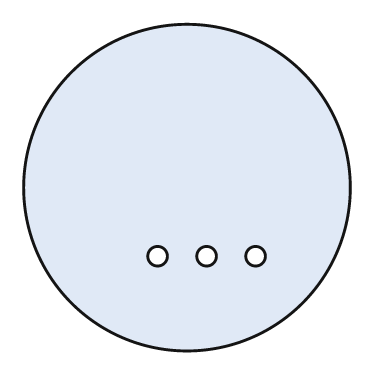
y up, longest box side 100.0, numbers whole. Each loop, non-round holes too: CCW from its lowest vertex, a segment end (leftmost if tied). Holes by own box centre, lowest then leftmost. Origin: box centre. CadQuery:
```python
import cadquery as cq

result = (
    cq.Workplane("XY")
    .moveTo(0.0, 0.0)
    .circle(50.0)
    .moveTo(-9.0, -21.0)
    .circle(3.0)
    .moveTo(6.0, -21.0)
    .circle(3.0)
    .moveTo(21.0, -21.0)
    .circle(3.0)
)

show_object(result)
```